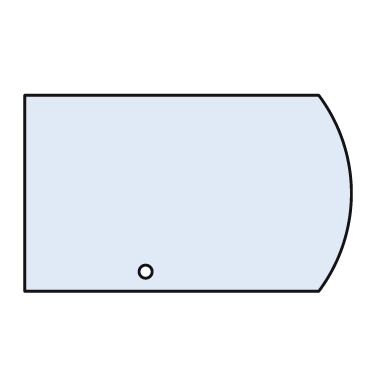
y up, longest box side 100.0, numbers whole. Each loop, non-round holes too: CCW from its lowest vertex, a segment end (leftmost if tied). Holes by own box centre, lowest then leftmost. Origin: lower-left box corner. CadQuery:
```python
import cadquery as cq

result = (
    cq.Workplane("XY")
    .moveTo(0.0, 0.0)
    .lineTo(90.0, 0.0)
    .threePointArc((100.0, 30.0), (90.0, 60.0))
    .lineTo(0.0, 60.0)
    .close()
    .moveTo(37.0, 6.0)
    .circle(2.0)
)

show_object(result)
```